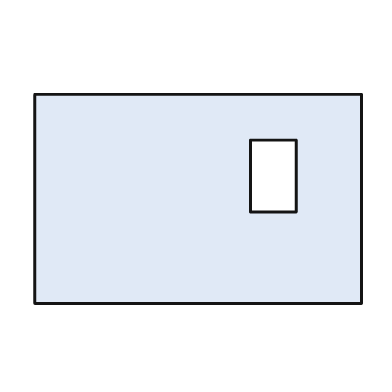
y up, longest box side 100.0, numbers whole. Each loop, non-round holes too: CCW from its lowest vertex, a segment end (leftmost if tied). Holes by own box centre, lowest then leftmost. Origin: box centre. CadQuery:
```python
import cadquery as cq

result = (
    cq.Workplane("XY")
    .moveTo(-50.0, -32.0)
    .lineTo(50.0, -32.0)
    .lineTo(50.0, 32.0)
    .lineTo(-50.0, 32.0)
    .close()
    .moveTo(16.0, -4.0)
    .lineTo(30.0, -4.0)
    .lineTo(30.0, 18.0)
    .lineTo(16.0, 18.0)
    .close()
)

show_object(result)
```